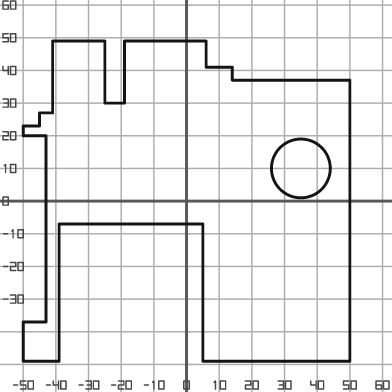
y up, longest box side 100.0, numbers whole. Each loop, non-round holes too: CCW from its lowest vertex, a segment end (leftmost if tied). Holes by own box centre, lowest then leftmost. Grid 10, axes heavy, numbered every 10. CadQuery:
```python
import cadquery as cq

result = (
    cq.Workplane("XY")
    .moveTo(-50.0, -49.0)
    .lineTo(-39.0, -49.0)
    .lineTo(-39.0, -7.0)
    .lineTo(5.0, -7.0)
    .lineTo(5.0, -49.0)
    .lineTo(50.0, -49.0)
    .lineTo(50.0, 37.0)
    .lineTo(14.0, 37.0)
    .lineTo(14.0, 41.0)
    .lineTo(6.0, 41.0)
    .lineTo(6.0, 49.0)
    .lineTo(-19.0, 49.0)
    .lineTo(-19.0, 30.0)
    .lineTo(-25.0, 30.0)
    .lineTo(-25.0, 49.0)
    .lineTo(-41.0, 49.0)
    .lineTo(-41.0, 27.0)
    .lineTo(-45.0, 27.0)
    .lineTo(-45.0, 23.0)
    .lineTo(-50.0, 23.0)
    .lineTo(-50.0, 20.0)
    .lineTo(-43.0, 20.0)
    .lineTo(-43.0, -37.0)
    .lineTo(-50.0, -37.0)
    .close()
    .moveTo(35.0, 10.0)
    .circle(9.0)
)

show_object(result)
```